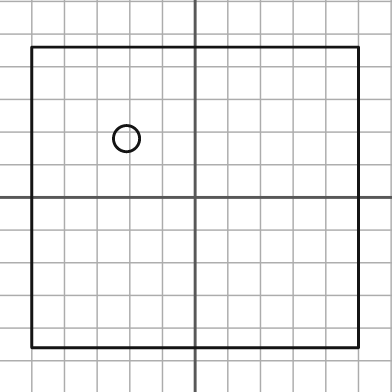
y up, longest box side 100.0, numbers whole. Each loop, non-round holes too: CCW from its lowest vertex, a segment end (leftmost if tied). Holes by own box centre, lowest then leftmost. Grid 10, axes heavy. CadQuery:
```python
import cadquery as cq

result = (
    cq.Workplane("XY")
    .moveTo(-50.0, -46.0)
    .lineTo(50.0, -46.0)
    .lineTo(50.0, 46.0)
    .lineTo(-50.0, 46.0)
    .close()
    .moveTo(-21.0, 18.0)
    .circle(4.0)
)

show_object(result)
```